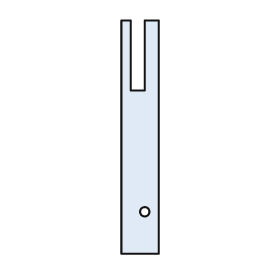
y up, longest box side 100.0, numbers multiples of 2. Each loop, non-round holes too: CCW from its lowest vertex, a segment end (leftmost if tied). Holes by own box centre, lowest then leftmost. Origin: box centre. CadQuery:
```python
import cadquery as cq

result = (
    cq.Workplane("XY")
    .moveTo(-8.0, -50.0)
    .lineTo(8.0, -50.0)
    .lineTo(8.0, 50.0)
    .lineTo(2.0, 50.0)
    .lineTo(2.0, 20.0)
    .lineTo(-4.0, 20.0)
    .lineTo(-4.0, 50.0)
    .lineTo(-8.0, 50.0)
    .close()
    .moveTo(2.0, -32.0)
    .circle(2.0)
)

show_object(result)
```